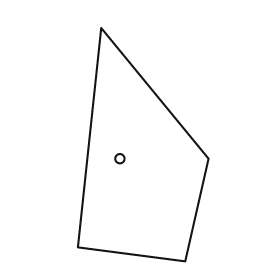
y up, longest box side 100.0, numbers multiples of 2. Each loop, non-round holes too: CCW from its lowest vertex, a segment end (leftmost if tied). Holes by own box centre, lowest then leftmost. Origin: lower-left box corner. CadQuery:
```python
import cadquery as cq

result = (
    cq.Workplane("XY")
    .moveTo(46.0, 0.0)
    .lineTo(56.0, 44.0)
    .lineTo(10.0, 100.0)
    .lineTo(0.0, 6.0)
    .close()
    .moveTo(18.0, 44.0)
    .circle(2.0)
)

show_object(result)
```